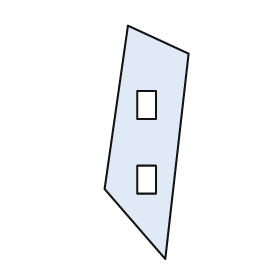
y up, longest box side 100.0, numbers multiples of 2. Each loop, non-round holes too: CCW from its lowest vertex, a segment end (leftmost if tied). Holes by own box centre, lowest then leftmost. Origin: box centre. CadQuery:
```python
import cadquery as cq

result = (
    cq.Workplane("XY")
    .moveTo(8.0, -50.0)
    .lineTo(18.0, 38.0)
    .lineTo(-8.0, 50.0)
    .lineTo(-18.0, -20.0)
    .close()
    .moveTo(-4.0, -22.0)
    .lineTo(4.0, -22.0)
    .lineTo(4.0, -10.0)
    .lineTo(-4.0, -10.0)
    .close()
    .moveTo(-4.0, 10.0)
    .lineTo(4.0, 10.0)
    .lineTo(4.0, 22.0)
    .lineTo(-4.0, 22.0)
    .close()
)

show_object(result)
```